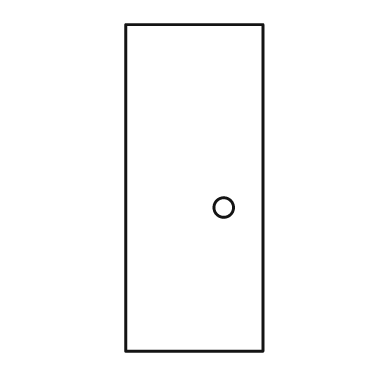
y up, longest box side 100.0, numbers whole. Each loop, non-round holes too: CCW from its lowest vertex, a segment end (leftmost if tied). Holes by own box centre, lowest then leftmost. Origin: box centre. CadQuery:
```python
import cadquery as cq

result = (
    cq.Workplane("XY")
    .moveTo(-21.0, -50.0)
    .lineTo(21.0, -50.0)
    .lineTo(21.0, 50.0)
    .lineTo(-21.0, 50.0)
    .close()
    .moveTo(9.0, -6.0)
    .circle(3.0)
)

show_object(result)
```